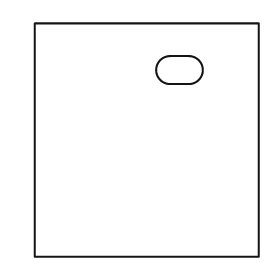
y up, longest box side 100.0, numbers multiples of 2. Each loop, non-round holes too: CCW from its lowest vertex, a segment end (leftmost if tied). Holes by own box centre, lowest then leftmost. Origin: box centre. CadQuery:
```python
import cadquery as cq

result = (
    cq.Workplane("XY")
    .moveTo(-48.0, -50.0)
    .lineTo(48.0, -50.0)
    .lineTo(48.0, 50.0)
    .lineTo(-48.0, 50.0)
    .close()
    .moveTo(10.0, 24.0)
    .lineTo(18.0, 24.0)
    .threePointArc((24.0, 30.0), (18.0, 36.0))
    .lineTo(10.0, 36.0)
    .threePointArc((4.0, 30.0), (10.0, 24.0))
    .close()
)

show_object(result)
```